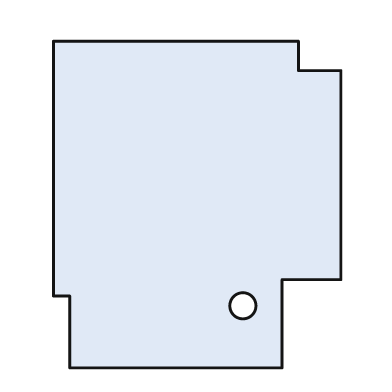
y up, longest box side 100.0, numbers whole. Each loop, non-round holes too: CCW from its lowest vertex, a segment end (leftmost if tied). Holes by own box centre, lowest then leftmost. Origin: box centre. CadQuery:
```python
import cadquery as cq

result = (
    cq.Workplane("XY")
    .moveTo(-39.0, -50.0)
    .lineTo(26.0, -50.0)
    .lineTo(26.0, -23.0)
    .lineTo(44.0, -23.0)
    .lineTo(44.0, 41.0)
    .lineTo(31.0, 41.0)
    .lineTo(31.0, 50.0)
    .lineTo(-44.0, 50.0)
    .lineTo(-44.0, -28.0)
    .lineTo(-39.0, -28.0)
    .close()
    .moveTo(14.0, -31.0)
    .circle(4.0)
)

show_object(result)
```